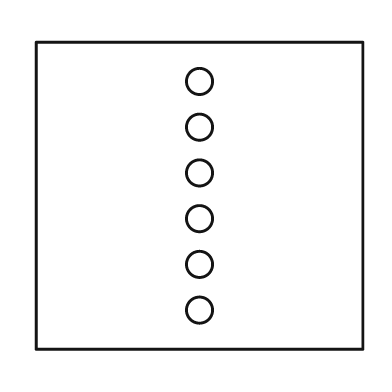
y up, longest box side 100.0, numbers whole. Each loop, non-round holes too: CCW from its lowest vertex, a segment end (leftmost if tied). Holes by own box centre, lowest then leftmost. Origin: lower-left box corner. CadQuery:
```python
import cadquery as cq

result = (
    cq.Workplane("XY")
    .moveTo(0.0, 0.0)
    .lineTo(100.0, 0.0)
    .lineTo(100.0, 94.0)
    .lineTo(0.0, 94.0)
    .close()
    .moveTo(50.0, 12.0)
    .circle(4.0)
    .moveTo(50.0, 26.0)
    .circle(4.0)
    .moveTo(50.0, 40.0)
    .circle(4.0)
    .moveTo(50.0, 54.0)
    .circle(4.0)
    .moveTo(50.0, 68.0)
    .circle(4.0)
    .moveTo(50.0, 82.0)
    .circle(4.0)
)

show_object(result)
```